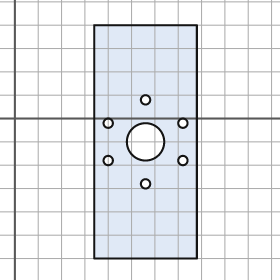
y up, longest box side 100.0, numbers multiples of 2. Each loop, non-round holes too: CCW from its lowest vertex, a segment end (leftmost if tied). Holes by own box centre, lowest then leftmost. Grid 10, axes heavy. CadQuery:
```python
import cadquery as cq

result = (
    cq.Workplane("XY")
    .moveTo(34.0, -60.0)
    .lineTo(78.0, -60.0)
    .lineTo(78.0, 40.0)
    .lineTo(34.0, 40.0)
    .close()
    .moveTo(56.0, -28.0)
    .circle(2.0)
    .moveTo(40.0, -18.0)
    .circle(2.0)
    .moveTo(72.0, -18.0)
    .circle(2.0)
    .moveTo(56.0, -10.0)
    .circle(8.0)
    .moveTo(40.0, -2.0)
    .circle(2.0)
    .moveTo(72.0, -2.0)
    .circle(2.0)
    .moveTo(56.0, 8.0)
    .circle(2.0)
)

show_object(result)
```